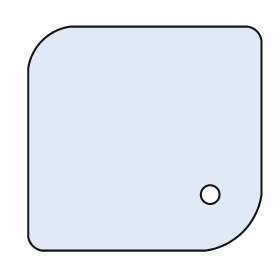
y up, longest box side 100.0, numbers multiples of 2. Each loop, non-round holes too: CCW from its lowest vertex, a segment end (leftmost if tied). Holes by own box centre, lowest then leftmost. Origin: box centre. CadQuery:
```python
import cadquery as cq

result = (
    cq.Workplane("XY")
    .moveTo(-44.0, -48.0)
    .lineTo(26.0, -48.0)
    .threePointArc((42.0, -40.0), (50.0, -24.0))
    .lineTo(50.0, 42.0)
    .threePointArc((48.0, 46.0), (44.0, 48.0))
    .lineTo(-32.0, 48.0)
    .threePointArc((-44.0, 42.0), (-50.0, 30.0))
    .lineTo(-50.0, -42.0)
    .threePointArc((-48.0, -46.0), (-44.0, -48.0))
    .close()
    .moveTo(28.0, -24.0)
    .circle(4.0)
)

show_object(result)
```